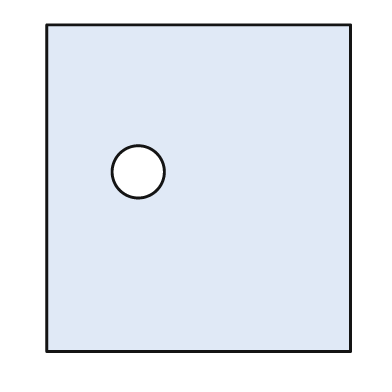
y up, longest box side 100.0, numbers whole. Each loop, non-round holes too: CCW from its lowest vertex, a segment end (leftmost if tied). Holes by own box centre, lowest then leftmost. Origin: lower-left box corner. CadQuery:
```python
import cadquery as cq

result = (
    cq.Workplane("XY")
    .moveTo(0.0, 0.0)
    .lineTo(93.0, 0.0)
    .lineTo(93.0, 100.0)
    .lineTo(0.0, 100.0)
    .close()
    .moveTo(28.0, 55.0)
    .circle(8.0)
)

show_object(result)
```